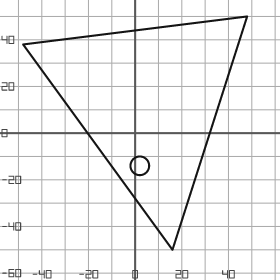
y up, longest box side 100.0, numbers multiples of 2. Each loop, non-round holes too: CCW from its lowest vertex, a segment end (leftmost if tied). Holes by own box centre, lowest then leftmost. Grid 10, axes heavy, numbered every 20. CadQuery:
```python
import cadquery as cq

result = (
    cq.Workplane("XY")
    .moveTo(16.0, -50.0)
    .lineTo(48.0, 50.0)
    .lineTo(-48.0, 38.0)
    .close()
    .moveTo(2.0, -14.0)
    .circle(4.0)
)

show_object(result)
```